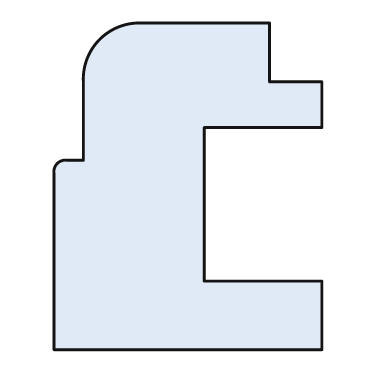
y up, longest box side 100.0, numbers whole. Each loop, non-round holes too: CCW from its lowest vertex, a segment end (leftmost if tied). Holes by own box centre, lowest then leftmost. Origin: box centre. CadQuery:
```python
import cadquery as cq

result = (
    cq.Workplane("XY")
    .moveTo(-41.0, -50.0)
    .lineTo(41.0, -50.0)
    .lineTo(41.0, -29.0)
    .lineTo(5.0, -29.0)
    .lineTo(5.0, 18.0)
    .lineTo(41.0, 18.0)
    .lineTo(41.0, 32.0)
    .lineTo(25.0, 32.0)
    .lineTo(25.0, 50.0)
    .lineTo(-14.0, 50.0)
    .threePointArc((-27.0, 45.0), (-32.0, 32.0))
    .lineTo(-32.0, 8.0)
    .lineTo(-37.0, 8.0)
    .threePointArc((-40.0, 7.0), (-41.0, 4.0))
    .close()
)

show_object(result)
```